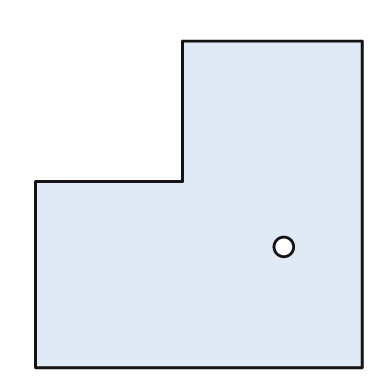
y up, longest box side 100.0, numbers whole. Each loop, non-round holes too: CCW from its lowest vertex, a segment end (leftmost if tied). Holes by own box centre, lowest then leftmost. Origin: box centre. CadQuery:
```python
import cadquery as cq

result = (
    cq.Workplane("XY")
    .moveTo(-50.0, -50.0)
    .lineTo(50.0, -50.0)
    .lineTo(50.0, 50.0)
    .lineTo(-5.0, 50.0)
    .lineTo(-5.0, 7.0)
    .lineTo(-50.0, 7.0)
    .close()
    .moveTo(26.0, -13.0)
    .circle(3.0)
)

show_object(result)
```